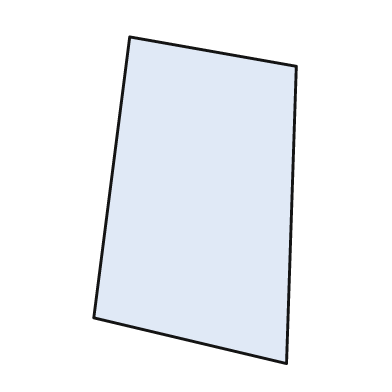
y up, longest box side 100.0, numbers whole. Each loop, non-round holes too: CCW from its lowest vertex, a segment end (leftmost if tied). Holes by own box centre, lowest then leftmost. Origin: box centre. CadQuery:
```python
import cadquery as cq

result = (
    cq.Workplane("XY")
    .moveTo(28.0, -50.0)
    .lineTo(31.0, 41.0)
    .lineTo(-20.0, 50.0)
    .lineTo(-31.0, -36.0)
    .close()
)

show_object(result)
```